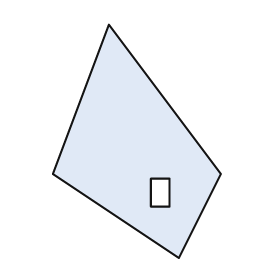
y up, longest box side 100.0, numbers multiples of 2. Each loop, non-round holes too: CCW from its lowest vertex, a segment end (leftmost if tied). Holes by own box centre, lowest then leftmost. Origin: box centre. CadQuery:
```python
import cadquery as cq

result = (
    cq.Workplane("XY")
    .moveTo(18.0, -50.0)
    .lineTo(36.0, -14.0)
    .lineTo(-12.0, 50.0)
    .lineTo(-36.0, -14.0)
    .close()
    .moveTo(6.0, -28.0)
    .lineTo(14.0, -28.0)
    .lineTo(14.0, -16.0)
    .lineTo(6.0, -16.0)
    .close()
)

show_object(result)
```